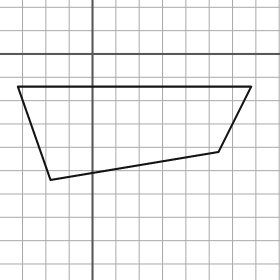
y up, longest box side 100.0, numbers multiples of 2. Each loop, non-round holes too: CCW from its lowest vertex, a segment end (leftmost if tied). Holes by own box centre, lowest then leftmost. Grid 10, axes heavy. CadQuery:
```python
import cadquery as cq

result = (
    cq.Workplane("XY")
    .moveTo(-18.0, -54.0)
    .lineTo(54.0, -42.0)
    .lineTo(68.0, -14.0)
    .lineTo(-32.0, -14.0)
    .close()
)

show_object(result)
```